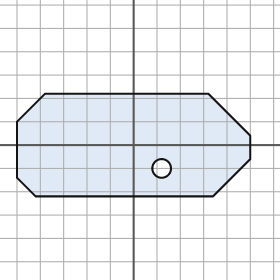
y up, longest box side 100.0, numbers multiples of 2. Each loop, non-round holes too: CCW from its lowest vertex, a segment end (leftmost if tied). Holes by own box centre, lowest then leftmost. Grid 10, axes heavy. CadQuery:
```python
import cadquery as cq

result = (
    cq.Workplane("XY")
    .moveTo(-42.0, -22.0)
    .lineTo(34.0, -22.0)
    .lineTo(50.0, -6.0)
    .lineTo(50.0, 4.0)
    .lineTo(32.0, 22.0)
    .lineTo(-38.0, 22.0)
    .lineTo(-50.0, 10.0)
    .lineTo(-50.0, -14.0)
    .close()
    .moveTo(12.0, -10.0)
    .circle(4.0)
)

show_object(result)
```